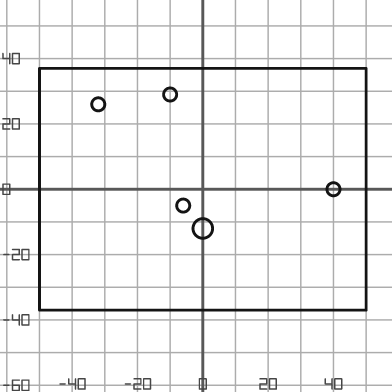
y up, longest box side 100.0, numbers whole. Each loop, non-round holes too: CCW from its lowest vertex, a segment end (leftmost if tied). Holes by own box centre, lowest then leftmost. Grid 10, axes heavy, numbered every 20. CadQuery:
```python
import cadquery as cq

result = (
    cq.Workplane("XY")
    .moveTo(-50.0, -37.0)
    .lineTo(50.0, -37.0)
    .lineTo(50.0, 37.0)
    .lineTo(-50.0, 37.0)
    .close()
    .moveTo(0.0, -12.0)
    .circle(3.0)
    .moveTo(-6.0, -5.0)
    .circle(2.0)
    .moveTo(40.0, 0.0)
    .circle(2.0)
    .moveTo(-32.0, 26.0)
    .circle(2.0)
    .moveTo(-10.0, 29.0)
    .circle(2.0)
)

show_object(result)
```